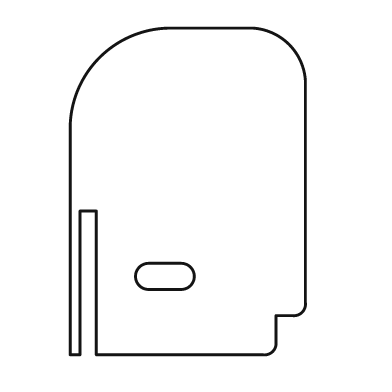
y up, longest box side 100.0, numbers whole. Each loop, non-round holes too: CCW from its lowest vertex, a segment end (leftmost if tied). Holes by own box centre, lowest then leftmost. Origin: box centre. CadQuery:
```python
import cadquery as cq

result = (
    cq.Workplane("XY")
    .moveTo(-36.0, -50.0)
    .lineTo(-33.0, -50.0)
    .lineTo(-33.0, -6.0)
    .lineTo(-28.0, -6.0)
    .lineTo(-28.0, -50.0)
    .lineTo(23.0, -50.0)
    .threePointArc((26.0, -49.0), (27.0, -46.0))
    .lineTo(27.0, -38.0)
    .lineTo(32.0, -38.0)
    .threePointArc((35.0, -37.0), (36.0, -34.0))
    .lineTo(36.0, 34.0)
    .threePointArc((31.0, 45.0), (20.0, 50.0))
    .lineTo(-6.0, 50.0)
    .threePointArc((-27.0, 41.0), (-36.0, 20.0))
    .close()
    .moveTo(-12.0, -30.0)
    .lineTo(-2.0, -30.0)
    .threePointArc((2.0, -26.0), (-2.0, -22.0))
    .lineTo(-12.0, -22.0)
    .threePointArc((-16.0, -26.0), (-12.0, -30.0))
    .close()
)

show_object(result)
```